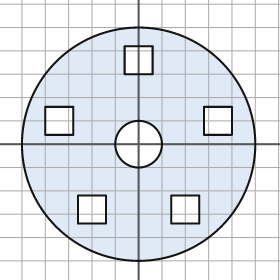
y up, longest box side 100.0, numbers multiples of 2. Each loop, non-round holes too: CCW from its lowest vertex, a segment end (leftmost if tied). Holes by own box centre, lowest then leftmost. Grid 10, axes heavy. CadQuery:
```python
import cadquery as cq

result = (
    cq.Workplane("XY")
    .moveTo(0.0, 0.0)
    .circle(50.0)
    .moveTo(-26.0, -34.0)
    .lineTo(-14.0, -34.0)
    .lineTo(-14.0, -22.0)
    .lineTo(-26.0, -22.0)
    .close()
    .moveTo(14.0, -34.0)
    .lineTo(26.0, -34.0)
    .lineTo(26.0, -22.0)
    .lineTo(14.0, -22.0)
    .close()
    .moveTo(0.0, 0.0)
    .circle(10.0)
    .moveTo(-40.0, 4.0)
    .lineTo(-28.0, 4.0)
    .lineTo(-28.0, 16.0)
    .lineTo(-40.0, 16.0)
    .close()
    .moveTo(28.0, 4.0)
    .lineTo(40.0, 4.0)
    .lineTo(40.0, 16.0)
    .lineTo(28.0, 16.0)
    .close()
    .moveTo(-6.0, 30.0)
    .lineTo(6.0, 30.0)
    .lineTo(6.0, 42.0)
    .lineTo(-6.0, 42.0)
    .close()
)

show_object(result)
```